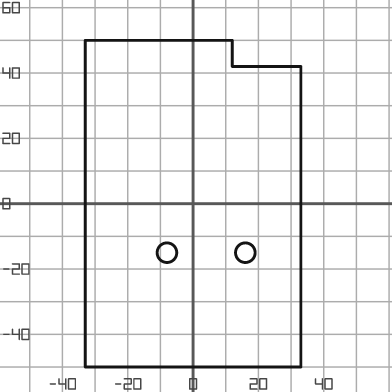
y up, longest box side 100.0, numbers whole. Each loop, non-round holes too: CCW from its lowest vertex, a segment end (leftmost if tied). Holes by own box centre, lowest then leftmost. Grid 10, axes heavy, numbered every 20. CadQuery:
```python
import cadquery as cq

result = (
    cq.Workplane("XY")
    .moveTo(-33.0, -50.0)
    .lineTo(33.0, -50.0)
    .lineTo(33.0, 42.0)
    .lineTo(12.0, 42.0)
    .lineTo(12.0, 50.0)
    .lineTo(-33.0, 50.0)
    .close()
    .moveTo(-8.0, -15.0)
    .circle(3.0)
    .moveTo(16.0, -15.0)
    .circle(3.0)
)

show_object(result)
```